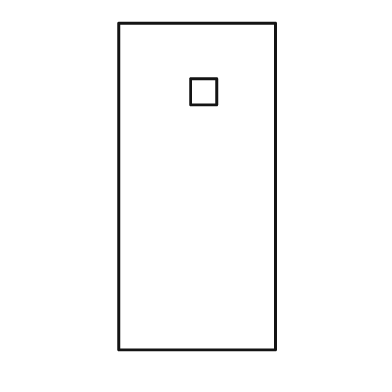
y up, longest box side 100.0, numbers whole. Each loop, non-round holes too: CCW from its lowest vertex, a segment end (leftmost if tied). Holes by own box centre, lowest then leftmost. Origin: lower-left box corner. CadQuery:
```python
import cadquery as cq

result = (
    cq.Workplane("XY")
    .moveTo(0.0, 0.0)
    .lineTo(48.0, 0.0)
    .lineTo(48.0, 100.0)
    .lineTo(0.0, 100.0)
    .close()
    .moveTo(22.0, 75.0)
    .lineTo(30.0, 75.0)
    .lineTo(30.0, 83.0)
    .lineTo(22.0, 83.0)
    .close()
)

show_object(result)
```